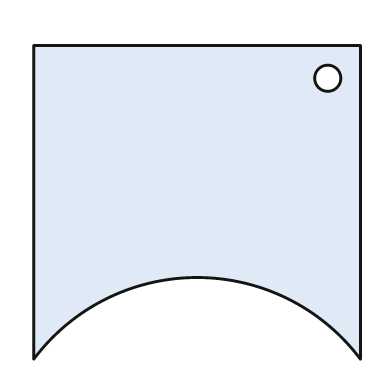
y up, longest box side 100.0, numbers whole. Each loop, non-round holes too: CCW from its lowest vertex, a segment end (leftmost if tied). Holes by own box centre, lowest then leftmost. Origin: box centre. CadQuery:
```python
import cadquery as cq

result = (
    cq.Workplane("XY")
    .moveTo(-50.0, -48.0)
    .threePointArc((0.0, -23.0), (50.0, -48.0))
    .lineTo(50.0, 48.0)
    .lineTo(-50.0, 48.0)
    .close()
    .moveTo(40.0, 38.0)
    .circle(4.0)
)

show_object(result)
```